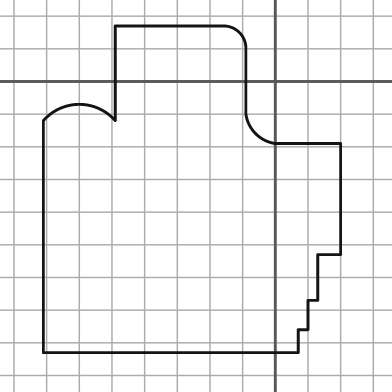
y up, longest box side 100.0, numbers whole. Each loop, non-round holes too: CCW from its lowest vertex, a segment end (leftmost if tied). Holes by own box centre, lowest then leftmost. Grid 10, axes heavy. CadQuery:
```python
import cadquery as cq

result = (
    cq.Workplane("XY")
    .moveTo(-71.0, -83.0)
    .lineTo(7.0, -83.0)
    .lineTo(7.0, -76.0)
    .lineTo(10.0, -76.0)
    .lineTo(10.0, -67.0)
    .lineTo(13.0, -67.0)
    .lineTo(13.0, -53.0)
    .lineTo(20.0, -53.0)
    .lineTo(20.0, -19.0)
    .lineTo(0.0, -19.0)
    .threePointArc((-6.0, -16.0), (-9.0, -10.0))
    .lineTo(-9.0, 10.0)
    .threePointArc((-11.0, 15.0), (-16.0, 17.0))
    .lineTo(-49.0, 17.0)
    .lineTo(-49.0, -12.0)
    .threePointArc((-60.0, -7.0), (-71.0, -12.0))
    .close()
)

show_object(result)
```